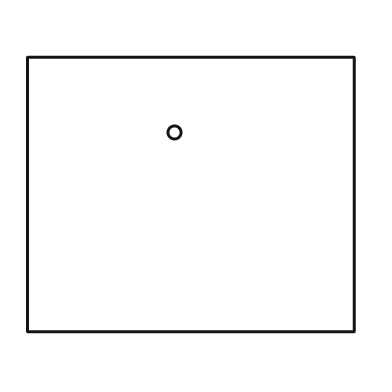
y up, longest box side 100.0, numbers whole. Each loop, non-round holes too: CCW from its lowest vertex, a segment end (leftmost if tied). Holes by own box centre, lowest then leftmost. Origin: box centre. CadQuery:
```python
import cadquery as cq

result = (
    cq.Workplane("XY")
    .moveTo(-50.0, -42.0)
    .lineTo(50.0, -42.0)
    .lineTo(50.0, 42.0)
    .lineTo(-50.0, 42.0)
    .close()
    .moveTo(-5.0, 19.0)
    .circle(2.0)
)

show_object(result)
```